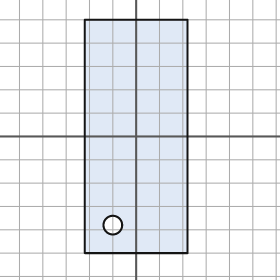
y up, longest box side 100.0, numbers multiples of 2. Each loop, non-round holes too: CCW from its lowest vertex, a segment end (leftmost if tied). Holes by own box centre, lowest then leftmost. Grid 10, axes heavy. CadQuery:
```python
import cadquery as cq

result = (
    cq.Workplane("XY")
    .moveTo(-22.0, -50.0)
    .lineTo(22.0, -50.0)
    .lineTo(22.0, 50.0)
    .lineTo(-22.0, 50.0)
    .close()
    .moveTo(-10.0, -38.0)
    .circle(4.0)
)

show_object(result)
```